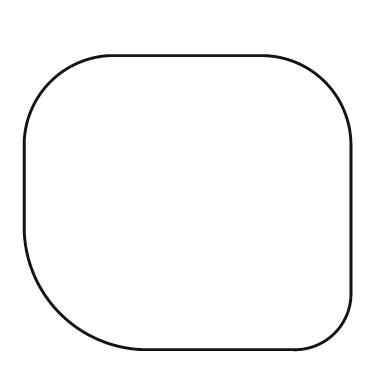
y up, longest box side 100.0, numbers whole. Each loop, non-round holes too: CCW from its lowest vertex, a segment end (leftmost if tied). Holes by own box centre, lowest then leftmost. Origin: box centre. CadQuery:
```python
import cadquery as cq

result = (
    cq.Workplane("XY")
    .moveTo(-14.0, -45.0)
    .lineTo(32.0, -45.0)
    .threePointArc((45.0, -40.0), (50.0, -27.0))
    .lineTo(50.0, 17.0)
    .threePointArc((42.0, 37.0), (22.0, 45.0))
    .lineTo(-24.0, 45.0)
    .threePointArc((-42.0, 37.0), (-50.0, 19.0))
    .lineTo(-50.0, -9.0)
    .threePointArc((-39.0, -34.0), (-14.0, -45.0))
    .close()
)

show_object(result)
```